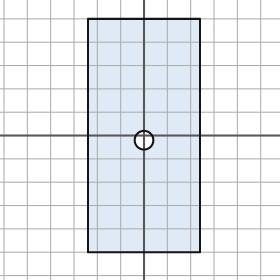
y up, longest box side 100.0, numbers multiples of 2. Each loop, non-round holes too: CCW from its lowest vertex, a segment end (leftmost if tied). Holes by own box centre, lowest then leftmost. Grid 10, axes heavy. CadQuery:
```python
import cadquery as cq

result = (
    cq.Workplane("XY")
    .moveTo(-24.0, -50.0)
    .lineTo(24.0, -50.0)
    .lineTo(24.0, 50.0)
    .lineTo(-24.0, 50.0)
    .close()
    .moveTo(0.0, -2.0)
    .circle(4.0)
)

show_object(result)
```